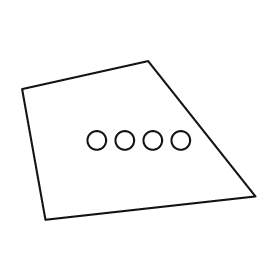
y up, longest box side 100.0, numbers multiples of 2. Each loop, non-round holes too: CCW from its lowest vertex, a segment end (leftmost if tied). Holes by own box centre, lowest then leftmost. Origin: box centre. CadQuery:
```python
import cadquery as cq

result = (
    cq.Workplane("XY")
    .moveTo(-40.0, -34.0)
    .lineTo(50.0, -24.0)
    .lineTo(4.0, 34.0)
    .lineTo(-50.0, 22.0)
    .close()
    .moveTo(-18.0, 0.0)
    .circle(4.0)
    .moveTo(-6.0, 0.0)
    .circle(4.0)
    .moveTo(6.0, 0.0)
    .circle(4.0)
    .moveTo(18.0, 0.0)
    .circle(4.0)
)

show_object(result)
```